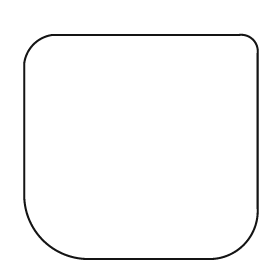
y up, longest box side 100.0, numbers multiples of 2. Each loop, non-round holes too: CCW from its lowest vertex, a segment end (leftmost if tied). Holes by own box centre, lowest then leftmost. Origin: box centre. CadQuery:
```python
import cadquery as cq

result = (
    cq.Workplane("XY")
    .moveTo(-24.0, -48.0)
    .lineTo(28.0, -48.0)
    .threePointArc((44.0, -42.0), (50.0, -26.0))
    .lineTo(50.0, 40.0)
    .threePointArc((48.0, 46.0), (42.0, 48.0))
    .lineTo(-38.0, 48.0)
    .threePointArc((-46.0, 44.0), (-50.0, 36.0))
    .lineTo(-50.0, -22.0)
    .threePointArc((-42.0, -40.0), (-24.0, -48.0))
    .close()
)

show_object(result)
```